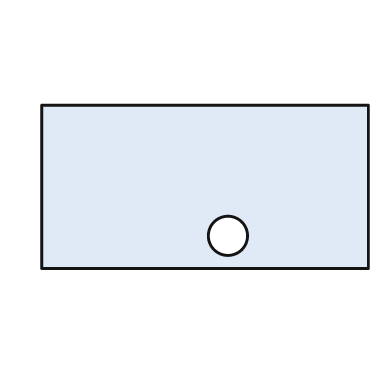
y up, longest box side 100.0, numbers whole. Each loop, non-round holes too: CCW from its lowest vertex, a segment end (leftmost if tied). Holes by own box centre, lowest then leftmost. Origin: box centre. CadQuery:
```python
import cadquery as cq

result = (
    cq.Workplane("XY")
    .moveTo(-50.0, -25.0)
    .lineTo(50.0, -25.0)
    .lineTo(50.0, 25.0)
    .lineTo(-50.0, 25.0)
    .close()
    .moveTo(7.0, -15.0)
    .circle(6.0)
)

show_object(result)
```